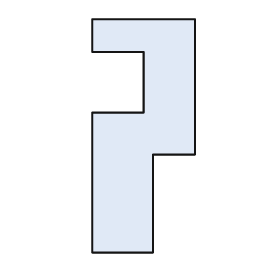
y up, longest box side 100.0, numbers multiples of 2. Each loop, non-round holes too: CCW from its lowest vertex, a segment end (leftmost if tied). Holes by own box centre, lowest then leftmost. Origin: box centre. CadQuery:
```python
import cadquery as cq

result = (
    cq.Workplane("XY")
    .moveTo(-22.0, -50.0)
    .lineTo(4.0, -50.0)
    .lineTo(4.0, -8.0)
    .lineTo(22.0, -8.0)
    .lineTo(22.0, 50.0)
    .lineTo(-22.0, 50.0)
    .lineTo(-22.0, 36.0)
    .lineTo(0.0, 36.0)
    .lineTo(0.0, 10.0)
    .lineTo(-22.0, 10.0)
    .close()
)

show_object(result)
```